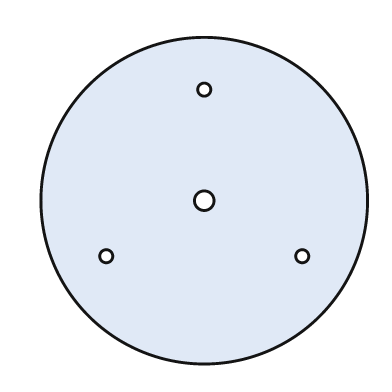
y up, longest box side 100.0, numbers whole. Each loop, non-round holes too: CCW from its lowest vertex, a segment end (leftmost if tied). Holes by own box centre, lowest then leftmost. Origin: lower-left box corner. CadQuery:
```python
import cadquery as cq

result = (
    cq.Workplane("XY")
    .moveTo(50.0, 50.0)
    .circle(50.0)
    .moveTo(20.0, 33.0)
    .circle(2.0)
    .moveTo(80.0, 33.0)
    .circle(2.0)
    .moveTo(50.0, 50.0)
    .circle(3.0)
    .moveTo(50.0, 84.0)
    .circle(2.0)
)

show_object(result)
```